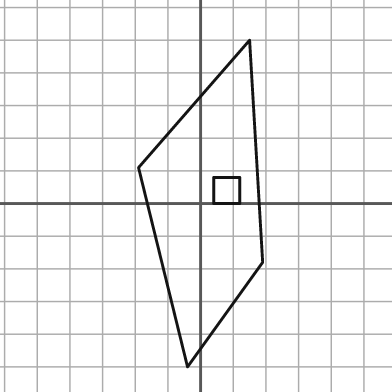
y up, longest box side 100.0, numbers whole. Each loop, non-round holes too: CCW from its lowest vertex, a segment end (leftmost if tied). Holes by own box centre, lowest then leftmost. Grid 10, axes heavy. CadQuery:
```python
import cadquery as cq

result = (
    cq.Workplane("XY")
    .moveTo(-4.0, -50.0)
    .lineTo(19.0, -18.0)
    .lineTo(15.0, 50.0)
    .lineTo(-19.0, 11.0)
    .close()
    .moveTo(4.0, 0.0)
    .lineTo(12.0, 0.0)
    .lineTo(12.0, 8.0)
    .lineTo(4.0, 8.0)
    .close()
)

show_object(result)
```